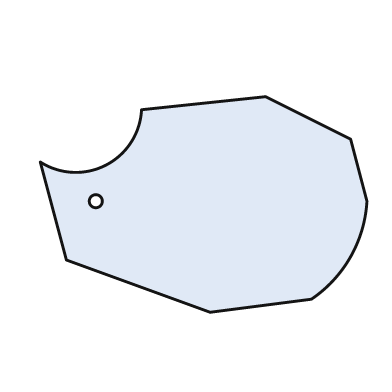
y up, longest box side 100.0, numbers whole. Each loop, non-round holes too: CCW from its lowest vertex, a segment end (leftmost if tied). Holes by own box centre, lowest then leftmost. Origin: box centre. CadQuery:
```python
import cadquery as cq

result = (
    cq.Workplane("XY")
    .moveTo(2.0, -33.0)
    .lineTo(33.0, -29.0)
    .threePointArc((45.0, -16.0), (50.0, 1.0))
    .lineTo(45.0, 20.0)
    .lineTo(19.0, 33.0)
    .lineTo(-19.0, 29.0)
    .threePointArc((-30.0, 12.0), (-50.0, 13.0))
    .lineTo(-42.0, -17.0)
    .close()
    .moveTo(-33.0, 1.0)
    .circle(2.0)
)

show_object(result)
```